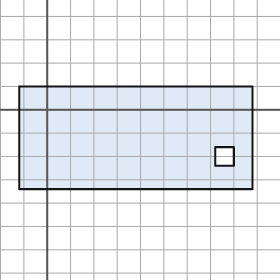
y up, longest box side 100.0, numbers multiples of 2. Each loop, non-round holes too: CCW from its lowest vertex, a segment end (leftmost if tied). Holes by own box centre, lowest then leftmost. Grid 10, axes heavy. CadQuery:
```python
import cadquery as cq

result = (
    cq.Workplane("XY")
    .moveTo(-12.0, -34.0)
    .lineTo(88.0, -34.0)
    .lineTo(88.0, 10.0)
    .lineTo(-12.0, 10.0)
    .close()
    .moveTo(72.0, -24.0)
    .lineTo(80.0, -24.0)
    .lineTo(80.0, -16.0)
    .lineTo(72.0, -16.0)
    .close()
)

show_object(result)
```